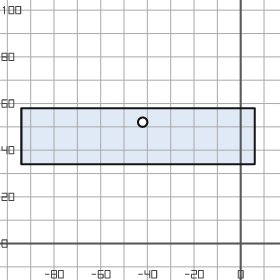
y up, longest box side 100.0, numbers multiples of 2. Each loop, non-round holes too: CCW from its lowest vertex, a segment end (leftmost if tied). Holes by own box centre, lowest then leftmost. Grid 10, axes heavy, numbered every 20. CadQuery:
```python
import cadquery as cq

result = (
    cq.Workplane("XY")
    .moveTo(-94.0, 34.0)
    .lineTo(6.0, 34.0)
    .lineTo(6.0, 58.0)
    .lineTo(-94.0, 58.0)
    .close()
    .moveTo(-42.0, 52.0)
    .circle(2.0)
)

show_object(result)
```